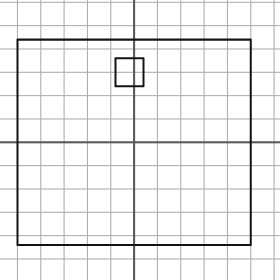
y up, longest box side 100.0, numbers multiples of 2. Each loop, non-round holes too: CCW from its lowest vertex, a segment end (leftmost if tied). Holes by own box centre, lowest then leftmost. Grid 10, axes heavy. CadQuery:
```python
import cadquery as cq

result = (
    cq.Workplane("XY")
    .moveTo(-50.0, -44.0)
    .lineTo(50.0, -44.0)
    .lineTo(50.0, 44.0)
    .lineTo(-50.0, 44.0)
    .close()
    .moveTo(-8.0, 24.0)
    .lineTo(4.0, 24.0)
    .lineTo(4.0, 36.0)
    .lineTo(-8.0, 36.0)
    .close()
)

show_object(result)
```